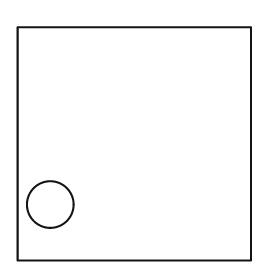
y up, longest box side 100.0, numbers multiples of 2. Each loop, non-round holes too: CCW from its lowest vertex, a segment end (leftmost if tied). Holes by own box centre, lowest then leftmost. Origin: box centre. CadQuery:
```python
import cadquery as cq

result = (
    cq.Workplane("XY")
    .moveTo(-50.0, -50.0)
    .lineTo(50.0, -50.0)
    .lineTo(50.0, 50.0)
    .lineTo(-50.0, 50.0)
    .close()
    .moveTo(-36.0, -26.0)
    .circle(10.0)
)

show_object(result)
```